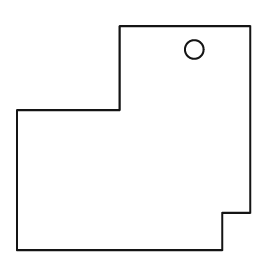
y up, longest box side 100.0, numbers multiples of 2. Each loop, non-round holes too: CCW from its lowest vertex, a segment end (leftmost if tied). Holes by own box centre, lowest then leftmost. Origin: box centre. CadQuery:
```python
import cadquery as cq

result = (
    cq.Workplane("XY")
    .moveTo(-50.0, -48.0)
    .lineTo(38.0, -48.0)
    .lineTo(38.0, -32.0)
    .lineTo(50.0, -32.0)
    .lineTo(50.0, 48.0)
    .lineTo(-6.0, 48.0)
    .lineTo(-6.0, 12.0)
    .lineTo(-50.0, 12.0)
    .close()
    .moveTo(26.0, 38.0)
    .circle(4.0)
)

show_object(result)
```